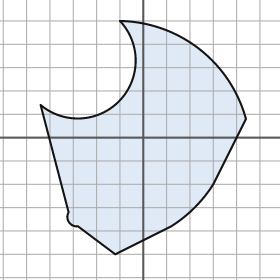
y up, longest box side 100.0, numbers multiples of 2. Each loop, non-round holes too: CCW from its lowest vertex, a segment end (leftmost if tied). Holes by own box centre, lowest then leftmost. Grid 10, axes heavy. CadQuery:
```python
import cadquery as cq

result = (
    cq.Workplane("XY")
    .moveTo(-12.0, -50.0)
    .lineTo(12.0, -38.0)
    .threePointArc((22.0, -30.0), (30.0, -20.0))
    .lineTo(44.0, 8.0)
    .threePointArc((24.0, 38.0), (-10.0, 50.0))
    .threePointArc((-10.0, 16.0), (-44.0, 14.0))
    .lineTo(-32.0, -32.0)
    .threePointArc((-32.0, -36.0), (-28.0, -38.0))
    .close()
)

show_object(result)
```